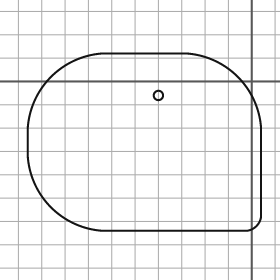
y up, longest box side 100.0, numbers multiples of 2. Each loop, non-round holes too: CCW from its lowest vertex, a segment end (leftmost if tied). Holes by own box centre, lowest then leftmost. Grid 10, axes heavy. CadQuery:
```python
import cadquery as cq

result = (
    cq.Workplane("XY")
    .moveTo(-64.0, -64.0)
    .lineTo(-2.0, -64.0)
    .threePointArc((2.0, -62.0), (4.0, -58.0))
    .lineTo(4.0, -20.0)
    .threePointArc((-6.0, 2.0), (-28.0, 12.0))
    .lineTo(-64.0, 12.0)
    .threePointArc((-86.0, 2.0), (-96.0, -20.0))
    .lineTo(-96.0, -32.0)
    .threePointArc((-86.0, -54.0), (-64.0, -64.0))
    .close()
    .moveTo(-40.0, -6.0)
    .circle(2.0)
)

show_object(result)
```